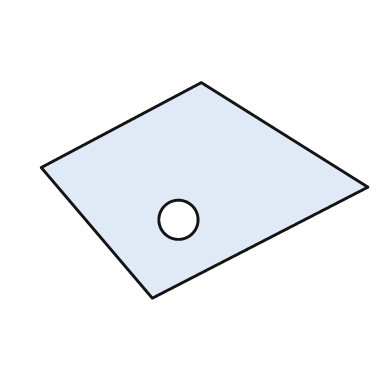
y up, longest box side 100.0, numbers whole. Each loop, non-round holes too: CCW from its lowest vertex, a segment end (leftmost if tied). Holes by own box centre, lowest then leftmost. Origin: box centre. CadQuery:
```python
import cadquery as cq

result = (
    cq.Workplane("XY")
    .moveTo(-16.0, -33.0)
    .lineTo(50.0, 1.0)
    .lineTo(-1.0, 33.0)
    .lineTo(-50.0, 7.0)
    .close()
    .moveTo(-8.0, -9.0)
    .circle(6.0)
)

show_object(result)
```